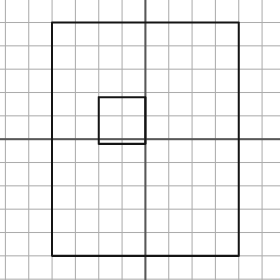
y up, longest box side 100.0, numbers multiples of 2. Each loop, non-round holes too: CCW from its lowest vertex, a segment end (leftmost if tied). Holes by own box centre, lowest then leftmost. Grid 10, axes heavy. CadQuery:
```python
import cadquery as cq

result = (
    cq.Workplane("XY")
    .moveTo(-40.0, -50.0)
    .lineTo(40.0, -50.0)
    .lineTo(40.0, 50.0)
    .lineTo(-40.0, 50.0)
    .close()
    .moveTo(-20.0, -2.0)
    .lineTo(0.0, -2.0)
    .lineTo(0.0, 18.0)
    .lineTo(-20.0, 18.0)
    .close()
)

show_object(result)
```